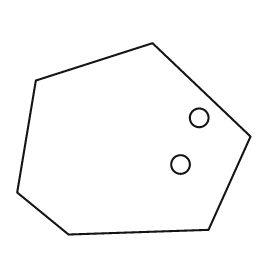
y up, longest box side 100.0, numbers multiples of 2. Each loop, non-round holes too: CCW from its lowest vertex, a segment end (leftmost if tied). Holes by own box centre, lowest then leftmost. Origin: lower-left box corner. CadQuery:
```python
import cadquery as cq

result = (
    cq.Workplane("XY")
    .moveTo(22.0, 0.0)
    .lineTo(82.0, 2.0)
    .lineTo(100.0, 42.0)
    .lineTo(58.0, 82.0)
    .lineTo(8.0, 66.0)
    .lineTo(0.0, 18.0)
    .close()
    .moveTo(70.0, 30.0)
    .circle(4.0)
    .moveTo(78.0, 50.0)
    .circle(4.0)
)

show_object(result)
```